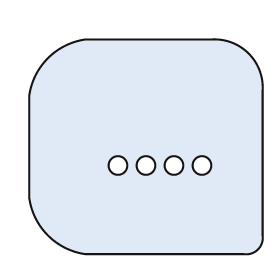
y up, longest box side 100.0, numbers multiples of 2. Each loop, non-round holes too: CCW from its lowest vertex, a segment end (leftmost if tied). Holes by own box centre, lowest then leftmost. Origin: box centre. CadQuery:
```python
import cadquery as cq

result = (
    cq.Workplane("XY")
    .moveTo(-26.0, -46.0)
    .lineTo(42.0, -46.0)
    .threePointArc((48.0, -44.0), (50.0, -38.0))
    .lineTo(50.0, 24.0)
    .threePointArc((44.0, 40.0), (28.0, 46.0))
    .lineTo(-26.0, 46.0)
    .threePointArc((-42.0, 38.0), (-50.0, 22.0))
    .lineTo(-50.0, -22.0)
    .threePointArc((-42.0, -38.0), (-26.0, -46.0))
    .close()
    .moveTo(-12.0, -8.0)
    .circle(4.0)
    .moveTo(0.0, -8.0)
    .circle(4.0)
    .moveTo(12.0, -8.0)
    .circle(4.0)
    .moveTo(24.0, -8.0)
    .circle(4.0)
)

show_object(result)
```